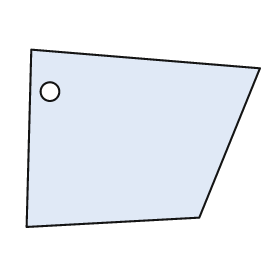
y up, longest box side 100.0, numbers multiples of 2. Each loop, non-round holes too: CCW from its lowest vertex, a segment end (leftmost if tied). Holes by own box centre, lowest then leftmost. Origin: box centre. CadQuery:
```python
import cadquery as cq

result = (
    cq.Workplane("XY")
    .moveTo(-50.0, -38.0)
    .lineTo(24.0, -34.0)
    .lineTo(50.0, 30.0)
    .lineTo(-48.0, 38.0)
    .close()
    .moveTo(-40.0, 20.0)
    .circle(4.0)
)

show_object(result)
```